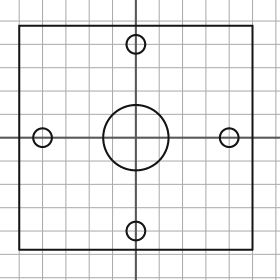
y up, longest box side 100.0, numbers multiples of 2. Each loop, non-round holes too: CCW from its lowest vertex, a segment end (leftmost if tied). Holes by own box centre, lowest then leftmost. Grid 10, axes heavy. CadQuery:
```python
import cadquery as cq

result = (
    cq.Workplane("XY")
    .moveTo(-50.0, -48.0)
    .lineTo(50.0, -48.0)
    .lineTo(50.0, 48.0)
    .lineTo(-50.0, 48.0)
    .close()
    .moveTo(0.0, -40.0)
    .circle(4.0)
    .moveTo(-40.0, 0.0)
    .circle(4.0)
    .moveTo(0.0, 0.0)
    .circle(14.0)
    .moveTo(40.0, 0.0)
    .circle(4.0)
    .moveTo(0.0, 40.0)
    .circle(4.0)
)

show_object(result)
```